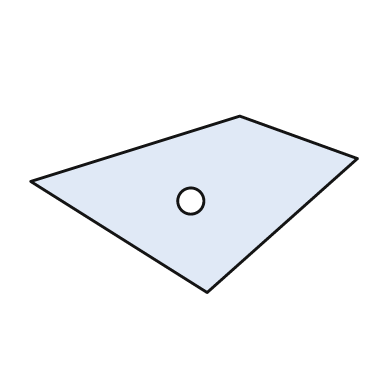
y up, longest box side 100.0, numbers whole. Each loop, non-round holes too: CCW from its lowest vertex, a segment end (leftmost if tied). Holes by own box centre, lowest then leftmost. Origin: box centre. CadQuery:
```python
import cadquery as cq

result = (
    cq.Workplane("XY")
    .moveTo(4.0, -27.0)
    .lineTo(50.0, 14.0)
    .lineTo(14.0, 27.0)
    .lineTo(-50.0, 7.0)
    .close()
    .moveTo(-1.0, 1.0)
    .circle(4.0)
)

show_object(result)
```